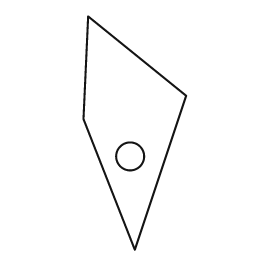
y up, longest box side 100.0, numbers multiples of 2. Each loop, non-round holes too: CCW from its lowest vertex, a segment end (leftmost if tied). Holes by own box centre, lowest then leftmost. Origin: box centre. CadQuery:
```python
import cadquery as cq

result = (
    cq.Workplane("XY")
    .moveTo(0.0, -50.0)
    .lineTo(22.0, 16.0)
    .lineTo(-20.0, 50.0)
    .lineTo(-22.0, 6.0)
    .close()
    .moveTo(-2.0, -10.0)
    .circle(6.0)
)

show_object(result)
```